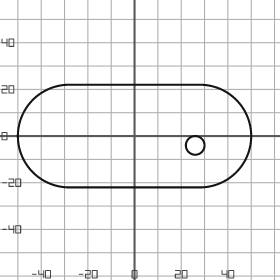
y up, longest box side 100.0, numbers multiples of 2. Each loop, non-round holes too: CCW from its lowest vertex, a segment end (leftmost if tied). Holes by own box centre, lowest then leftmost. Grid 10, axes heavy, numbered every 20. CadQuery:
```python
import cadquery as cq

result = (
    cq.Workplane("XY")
    .moveTo(-28.0, -22.0)
    .lineTo(28.0, -22.0)
    .threePointArc((50.0, 0.0), (28.0, 22.0))
    .lineTo(-28.0, 22.0)
    .threePointArc((-50.0, 0.0), (-28.0, -22.0))
    .close()
    .moveTo(26.0, -4.0)
    .circle(4.0)
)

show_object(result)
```